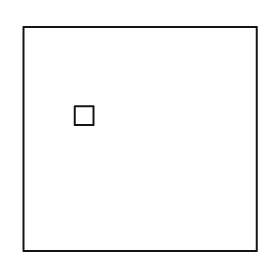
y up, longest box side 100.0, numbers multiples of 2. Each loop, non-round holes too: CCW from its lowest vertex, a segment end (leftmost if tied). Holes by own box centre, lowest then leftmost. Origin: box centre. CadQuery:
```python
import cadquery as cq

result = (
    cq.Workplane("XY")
    .moveTo(-50.0, -48.0)
    .lineTo(50.0, -48.0)
    .lineTo(50.0, 48.0)
    .lineTo(-50.0, 48.0)
    .close()
    .moveTo(-28.0, 6.0)
    .lineTo(-20.0, 6.0)
    .lineTo(-20.0, 14.0)
    .lineTo(-28.0, 14.0)
    .close()
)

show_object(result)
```